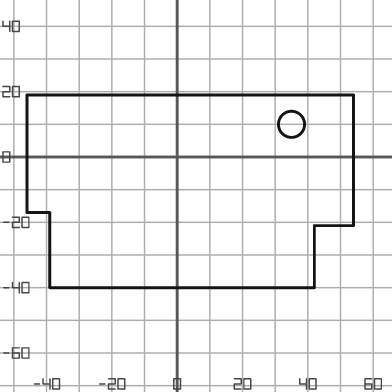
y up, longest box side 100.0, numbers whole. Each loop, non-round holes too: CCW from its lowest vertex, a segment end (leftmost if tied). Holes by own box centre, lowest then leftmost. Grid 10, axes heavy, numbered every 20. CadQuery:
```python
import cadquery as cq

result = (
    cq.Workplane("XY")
    .moveTo(-39.0, -40.0)
    .lineTo(42.0, -40.0)
    .lineTo(42.0, -21.0)
    .lineTo(54.0, -21.0)
    .lineTo(54.0, 19.0)
    .lineTo(-46.0, 19.0)
    .lineTo(-46.0, -17.0)
    .lineTo(-39.0, -17.0)
    .close()
    .moveTo(35.0, 10.0)
    .circle(4.0)
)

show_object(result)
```